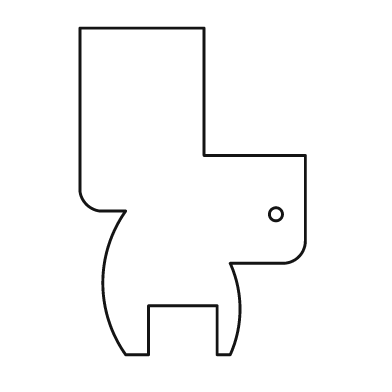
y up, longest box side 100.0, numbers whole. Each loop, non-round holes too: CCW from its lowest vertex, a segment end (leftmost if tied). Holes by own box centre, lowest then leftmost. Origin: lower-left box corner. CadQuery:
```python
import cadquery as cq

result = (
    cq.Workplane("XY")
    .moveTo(14.0, 0.0)
    .lineTo(21.0, 0.0)
    .lineTo(21.0, 15.0)
    .lineTo(42.0, 15.0)
    .lineTo(42.0, 0.0)
    .lineTo(46.0, 0.0)
    .threePointArc((49.0, 14.0), (46.0, 28.0))
    .lineTo(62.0, 28.0)
    .threePointArc((67.0, 30.0), (69.0, 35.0))
    .lineTo(69.0, 61.0)
    .lineTo(38.0, 61.0)
    .lineTo(38.0, 100.0)
    .lineTo(0.0, 100.0)
    .lineTo(0.0, 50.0)
    .threePointArc((2.0, 46.0), (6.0, 44.0))
    .lineTo(14.0, 44.0)
    .threePointArc((7.0, 22.0), (14.0, 0.0))
    .close()
    .moveTo(60.0, 43.0)
    .circle(2.0)
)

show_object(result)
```